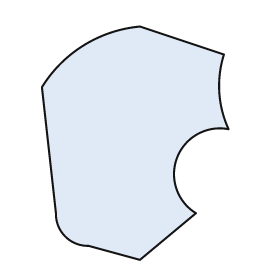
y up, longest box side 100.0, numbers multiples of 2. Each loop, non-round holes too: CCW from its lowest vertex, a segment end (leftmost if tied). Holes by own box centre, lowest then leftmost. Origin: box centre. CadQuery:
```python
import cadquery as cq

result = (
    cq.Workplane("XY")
    .moveTo(2.0, -50.0)
    .lineTo(26.0, -30.0)
    .threePointArc((18.0, -6.0), (40.0, 6.0))
    .threePointArc((36.0, 22.0), (38.0, 38.0))
    .lineTo(2.0, 50.0)
    .threePointArc((-22.0, 42.0), (-40.0, 24.0))
    .lineTo(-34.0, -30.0)
    .threePointArc((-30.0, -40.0), (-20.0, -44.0))
    .close()
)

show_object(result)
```